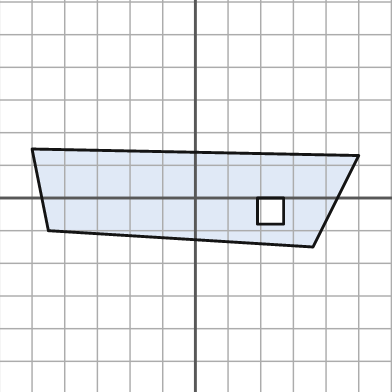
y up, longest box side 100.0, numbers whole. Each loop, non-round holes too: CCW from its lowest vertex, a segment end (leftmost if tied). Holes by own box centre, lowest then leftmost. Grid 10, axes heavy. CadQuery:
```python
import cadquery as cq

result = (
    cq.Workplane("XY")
    .moveTo(36.0, -15.0)
    .lineTo(50.0, 13.0)
    .lineTo(-50.0, 15.0)
    .lineTo(-45.0, -10.0)
    .close()
    .moveTo(19.0, -8.0)
    .lineTo(27.0, -8.0)
    .lineTo(27.0, 0.0)
    .lineTo(19.0, 0.0)
    .close()
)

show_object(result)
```